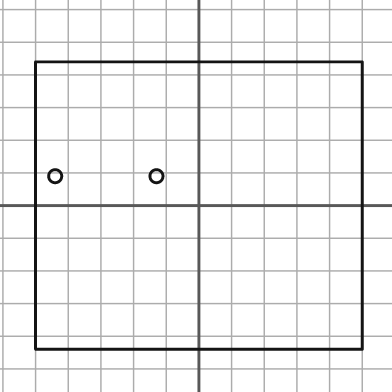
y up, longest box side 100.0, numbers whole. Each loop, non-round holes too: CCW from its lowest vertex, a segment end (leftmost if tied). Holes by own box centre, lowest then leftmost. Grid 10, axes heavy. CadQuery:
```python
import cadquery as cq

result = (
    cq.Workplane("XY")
    .moveTo(-50.0, -44.0)
    .lineTo(50.0, -44.0)
    .lineTo(50.0, 44.0)
    .lineTo(-50.0, 44.0)
    .close()
    .moveTo(-44.0, 9.0)
    .circle(2.0)
    .moveTo(-13.0, 9.0)
    .circle(2.0)
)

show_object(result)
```